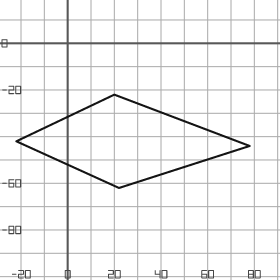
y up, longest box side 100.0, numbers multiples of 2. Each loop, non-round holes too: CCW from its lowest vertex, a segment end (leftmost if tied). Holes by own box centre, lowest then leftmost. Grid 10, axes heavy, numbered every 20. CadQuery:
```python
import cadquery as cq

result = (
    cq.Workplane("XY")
    .moveTo(22.0, -62.0)
    .lineTo(78.0, -44.0)
    .lineTo(20.0, -22.0)
    .lineTo(-22.0, -42.0)
    .close()
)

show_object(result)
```